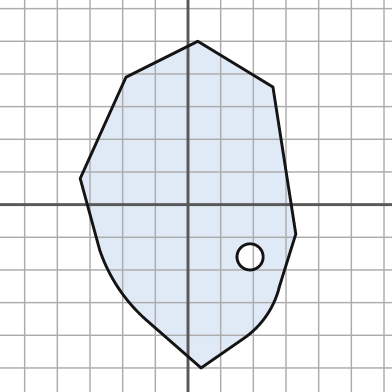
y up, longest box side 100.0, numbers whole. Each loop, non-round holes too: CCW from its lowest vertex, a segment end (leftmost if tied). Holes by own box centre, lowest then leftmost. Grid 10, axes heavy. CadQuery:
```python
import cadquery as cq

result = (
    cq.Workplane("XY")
    .moveTo(4.0, -50.0)
    .lineTo(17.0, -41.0)
    .threePointArc((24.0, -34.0), (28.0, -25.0))
    .lineTo(33.0, -9.0)
    .lineTo(26.0, 36.0)
    .lineTo(3.0, 50.0)
    .lineTo(-19.0, 39.0)
    .lineTo(-33.0, 8.0)
    .lineTo(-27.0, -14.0)
    .threePointArc((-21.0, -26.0), (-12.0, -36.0))
    .close()
    .moveTo(19.0, -16.0)
    .circle(4.0)
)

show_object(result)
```